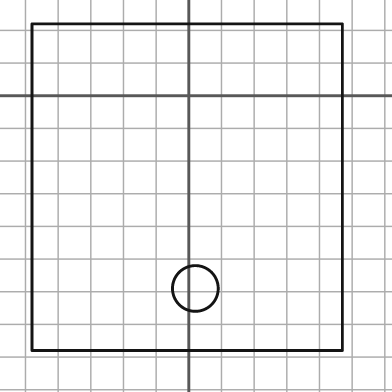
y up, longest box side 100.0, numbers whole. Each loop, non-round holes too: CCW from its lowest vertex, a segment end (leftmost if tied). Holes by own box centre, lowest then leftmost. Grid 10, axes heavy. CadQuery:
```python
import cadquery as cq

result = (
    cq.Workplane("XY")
    .moveTo(-48.0, -78.0)
    .lineTo(47.0, -78.0)
    .lineTo(47.0, 22.0)
    .lineTo(-48.0, 22.0)
    .close()
    .moveTo(2.0, -59.0)
    .circle(7.0)
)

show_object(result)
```